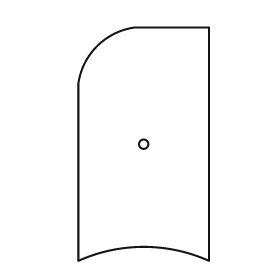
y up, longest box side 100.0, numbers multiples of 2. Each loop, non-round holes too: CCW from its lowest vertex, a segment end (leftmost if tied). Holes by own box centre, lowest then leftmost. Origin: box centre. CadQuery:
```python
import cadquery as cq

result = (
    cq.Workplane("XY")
    .moveTo(-28.0, -50.0)
    .threePointArc((0.0, -44.0), (28.0, -50.0))
    .lineTo(28.0, 50.0)
    .lineTo(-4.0, 50.0)
    .threePointArc((-20.0, 42.0), (-28.0, 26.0))
    .close()
    .moveTo(0.0, 0.0)
    .circle(2.0)
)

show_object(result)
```